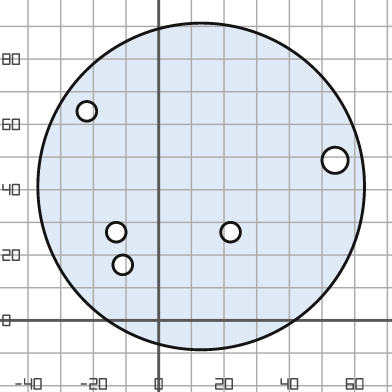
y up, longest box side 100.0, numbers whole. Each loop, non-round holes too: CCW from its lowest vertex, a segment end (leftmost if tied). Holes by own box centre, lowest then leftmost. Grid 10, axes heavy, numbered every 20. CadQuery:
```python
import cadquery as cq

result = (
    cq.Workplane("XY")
    .moveTo(13.0, 41.0)
    .circle(50.0)
    .moveTo(-11.0, 17.0)
    .circle(3.0)
    .moveTo(-13.0, 27.0)
    .circle(3.0)
    .moveTo(22.0, 27.0)
    .circle(3.0)
    .moveTo(54.0, 49.0)
    .circle(4.0)
    .moveTo(-22.0, 64.0)
    .circle(3.0)
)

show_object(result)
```